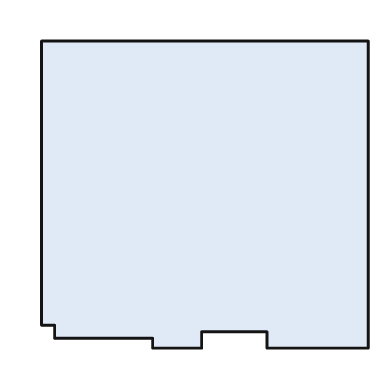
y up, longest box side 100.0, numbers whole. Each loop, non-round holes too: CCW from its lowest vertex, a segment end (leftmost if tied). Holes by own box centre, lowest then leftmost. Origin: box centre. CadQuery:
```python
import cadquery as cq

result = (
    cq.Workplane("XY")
    .moveTo(-16.0, -47.0)
    .lineTo(-1.0, -47.0)
    .lineTo(-1.0, -42.0)
    .lineTo(19.0, -42.0)
    .lineTo(19.0, -47.0)
    .lineTo(50.0, -47.0)
    .lineTo(50.0, 47.0)
    .lineTo(-50.0, 47.0)
    .lineTo(-50.0, -40.0)
    .lineTo(-46.0, -40.0)
    .lineTo(-46.0, -44.0)
    .lineTo(-16.0, -44.0)
    .close()
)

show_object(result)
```